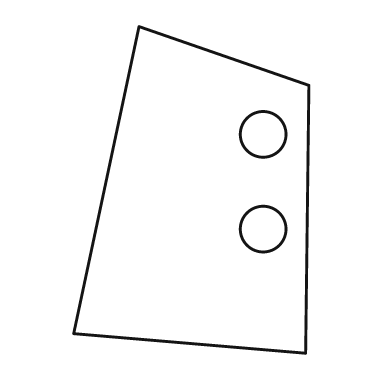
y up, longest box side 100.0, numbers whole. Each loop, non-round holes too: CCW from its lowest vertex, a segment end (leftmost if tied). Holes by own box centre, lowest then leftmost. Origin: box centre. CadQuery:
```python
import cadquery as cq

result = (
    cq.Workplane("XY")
    .moveTo(35.0, -50.0)
    .lineTo(36.0, 32.0)
    .lineTo(-16.0, 50.0)
    .lineTo(-36.0, -44.0)
    .close()
    .moveTo(22.0, -12.0)
    .circle(7.0)
    .moveTo(22.0, 17.0)
    .circle(7.0)
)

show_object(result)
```